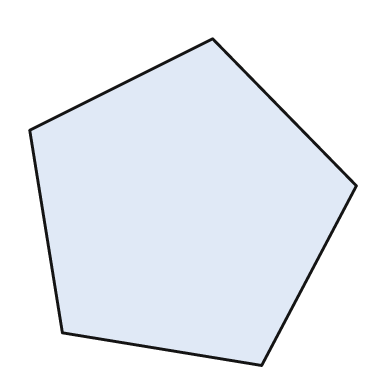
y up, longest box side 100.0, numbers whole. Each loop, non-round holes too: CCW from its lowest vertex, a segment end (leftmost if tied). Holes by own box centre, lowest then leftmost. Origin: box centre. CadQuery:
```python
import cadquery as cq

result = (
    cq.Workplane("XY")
    .moveTo(21.0, -50.0)
    .lineTo(50.0, 5.0)
    .lineTo(6.0, 50.0)
    .lineTo(-50.0, 22.0)
    .lineTo(-40.0, -40.0)
    .close()
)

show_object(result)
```